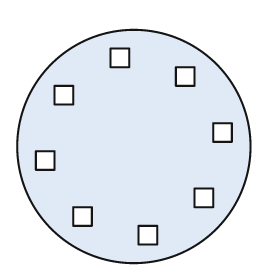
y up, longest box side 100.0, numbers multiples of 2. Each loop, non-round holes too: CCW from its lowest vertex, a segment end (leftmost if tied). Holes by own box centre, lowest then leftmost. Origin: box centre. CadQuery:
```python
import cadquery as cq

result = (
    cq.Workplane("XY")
    .moveTo(0.0, 0.0)
    .circle(50.0)
    .moveTo(2.0, -42.0)
    .lineTo(10.0, -42.0)
    .lineTo(10.0, -34.0)
    .lineTo(2.0, -34.0)
    .close()
    .moveTo(-26.0, -34.0)
    .lineTo(-18.0, -34.0)
    .lineTo(-18.0, -26.0)
    .lineTo(-26.0, -26.0)
    .close()
    .moveTo(26.0, -26.0)
    .lineTo(34.0, -26.0)
    .lineTo(34.0, -18.0)
    .lineTo(26.0, -18.0)
    .close()
    .moveTo(-42.0, -10.0)
    .lineTo(-34.0, -10.0)
    .lineTo(-34.0, -2.0)
    .lineTo(-42.0, -2.0)
    .close()
    .moveTo(34.0, 2.0)
    .lineTo(42.0, 2.0)
    .lineTo(42.0, 10.0)
    .lineTo(34.0, 10.0)
    .close()
    .moveTo(-34.0, 18.0)
    .lineTo(-26.0, 18.0)
    .lineTo(-26.0, 26.0)
    .lineTo(-34.0, 26.0)
    .close()
    .moveTo(18.0, 26.0)
    .lineTo(26.0, 26.0)
    .lineTo(26.0, 34.0)
    .lineTo(18.0, 34.0)
    .close()
    .moveTo(-10.0, 34.0)
    .lineTo(-2.0, 34.0)
    .lineTo(-2.0, 42.0)
    .lineTo(-10.0, 42.0)
    .close()
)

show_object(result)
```